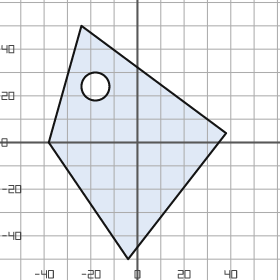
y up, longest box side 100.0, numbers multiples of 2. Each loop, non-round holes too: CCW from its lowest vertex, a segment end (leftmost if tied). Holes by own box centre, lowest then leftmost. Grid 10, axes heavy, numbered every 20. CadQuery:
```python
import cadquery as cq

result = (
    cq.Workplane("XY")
    .moveTo(-4.0, -50.0)
    .lineTo(38.0, 4.0)
    .lineTo(-24.0, 50.0)
    .lineTo(-38.0, 0.0)
    .close()
    .moveTo(-18.0, 24.0)
    .circle(6.0)
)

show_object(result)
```